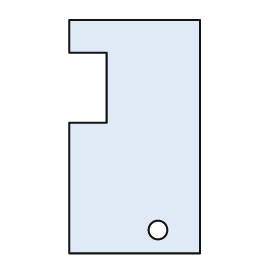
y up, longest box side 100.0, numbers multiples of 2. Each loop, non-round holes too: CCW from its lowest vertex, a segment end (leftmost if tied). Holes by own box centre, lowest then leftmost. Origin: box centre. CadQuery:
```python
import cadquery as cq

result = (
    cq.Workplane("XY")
    .moveTo(-28.0, -50.0)
    .lineTo(28.0, -50.0)
    .lineTo(28.0, 50.0)
    .lineTo(-28.0, 50.0)
    .lineTo(-28.0, 36.0)
    .lineTo(-12.0, 36.0)
    .lineTo(-12.0, 6.0)
    .lineTo(-28.0, 6.0)
    .close()
    .moveTo(10.0, -40.0)
    .circle(4.0)
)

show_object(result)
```